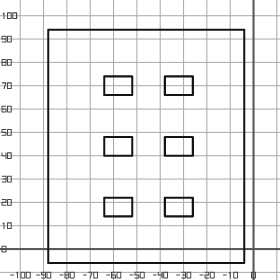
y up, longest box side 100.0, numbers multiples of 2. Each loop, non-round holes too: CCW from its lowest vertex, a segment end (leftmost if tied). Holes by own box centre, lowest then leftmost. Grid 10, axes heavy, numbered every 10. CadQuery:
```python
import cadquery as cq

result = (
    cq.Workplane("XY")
    .moveTo(-88.0, -6.0)
    .lineTo(-4.0, -6.0)
    .lineTo(-4.0, 94.0)
    .lineTo(-88.0, 94.0)
    .close()
    .moveTo(-64.0, 14.0)
    .lineTo(-52.0, 14.0)
    .lineTo(-52.0, 22.0)
    .lineTo(-64.0, 22.0)
    .close()
    .moveTo(-38.0, 14.0)
    .lineTo(-26.0, 14.0)
    .lineTo(-26.0, 22.0)
    .lineTo(-38.0, 22.0)
    .close()
    .moveTo(-64.0, 40.0)
    .lineTo(-52.0, 40.0)
    .lineTo(-52.0, 48.0)
    .lineTo(-64.0, 48.0)
    .close()
    .moveTo(-38.0, 40.0)
    .lineTo(-26.0, 40.0)
    .lineTo(-26.0, 48.0)
    .lineTo(-38.0, 48.0)
    .close()
    .moveTo(-64.0, 66.0)
    .lineTo(-52.0, 66.0)
    .lineTo(-52.0, 74.0)
    .lineTo(-64.0, 74.0)
    .close()
    .moveTo(-38.0, 66.0)
    .lineTo(-26.0, 66.0)
    .lineTo(-26.0, 74.0)
    .lineTo(-38.0, 74.0)
    .close()
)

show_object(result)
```